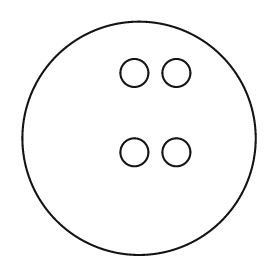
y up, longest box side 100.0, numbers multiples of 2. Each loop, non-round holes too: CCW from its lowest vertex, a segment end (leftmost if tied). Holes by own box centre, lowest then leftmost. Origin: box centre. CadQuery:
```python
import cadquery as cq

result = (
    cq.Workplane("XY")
    .moveTo(0.0, 0.0)
    .circle(50.0)
    .moveTo(-2.0, -6.0)
    .circle(6.0)
    .moveTo(16.0, -6.0)
    .circle(6.0)
    .moveTo(-2.0, 28.0)
    .circle(6.0)
    .moveTo(16.0, 28.0)
    .circle(6.0)
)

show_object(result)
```